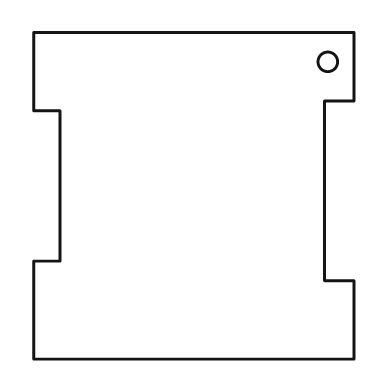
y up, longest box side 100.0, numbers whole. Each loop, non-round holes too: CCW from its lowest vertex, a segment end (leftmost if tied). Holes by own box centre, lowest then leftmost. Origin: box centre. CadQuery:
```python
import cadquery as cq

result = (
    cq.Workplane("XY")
    .moveTo(-49.0, -50.0)
    .lineTo(49.0, -50.0)
    .lineTo(49.0, -26.0)
    .lineTo(40.0, -26.0)
    .lineTo(40.0, 29.0)
    .lineTo(49.0, 29.0)
    .lineTo(49.0, 50.0)
    .lineTo(-49.0, 50.0)
    .lineTo(-49.0, 26.0)
    .lineTo(-41.0, 26.0)
    .lineTo(-41.0, -20.0)
    .lineTo(-49.0, -20.0)
    .close()
    .moveTo(41.0, 41.0)
    .circle(3.0)
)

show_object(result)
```